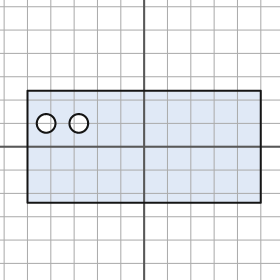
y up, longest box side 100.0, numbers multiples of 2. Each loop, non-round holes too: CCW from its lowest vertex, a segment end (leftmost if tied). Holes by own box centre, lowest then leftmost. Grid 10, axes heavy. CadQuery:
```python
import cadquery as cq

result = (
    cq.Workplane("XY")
    .moveTo(-50.0, -24.0)
    .lineTo(50.0, -24.0)
    .lineTo(50.0, 24.0)
    .lineTo(-50.0, 24.0)
    .close()
    .moveTo(-42.0, 10.0)
    .circle(4.0)
    .moveTo(-28.0, 10.0)
    .circle(4.0)
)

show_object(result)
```